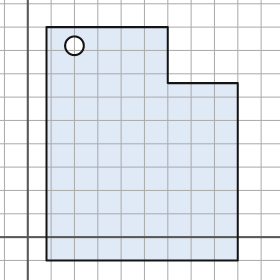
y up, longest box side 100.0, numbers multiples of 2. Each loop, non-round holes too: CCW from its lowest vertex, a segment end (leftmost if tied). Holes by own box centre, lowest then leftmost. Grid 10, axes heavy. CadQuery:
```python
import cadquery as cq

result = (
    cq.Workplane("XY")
    .moveTo(8.0, -10.0)
    .lineTo(90.0, -10.0)
    .lineTo(90.0, 66.0)
    .lineTo(60.0, 66.0)
    .lineTo(60.0, 90.0)
    .lineTo(8.0, 90.0)
    .close()
    .moveTo(20.0, 82.0)
    .circle(4.0)
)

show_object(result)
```